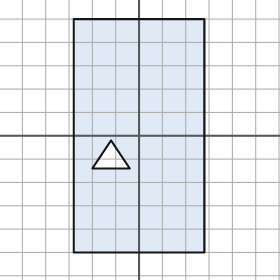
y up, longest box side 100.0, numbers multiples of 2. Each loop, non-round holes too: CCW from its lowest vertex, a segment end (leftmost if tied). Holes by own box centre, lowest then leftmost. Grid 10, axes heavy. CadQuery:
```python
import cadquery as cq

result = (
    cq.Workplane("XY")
    .moveTo(-28.0, -50.0)
    .lineTo(28.0, -50.0)
    .lineTo(28.0, 50.0)
    .lineTo(-28.0, 50.0)
    .close()
    .moveTo(-20.0, -14.0)
    .lineTo(-4.0, -14.0)
    .lineTo(-12.0, -2.0)
    .close()
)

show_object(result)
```